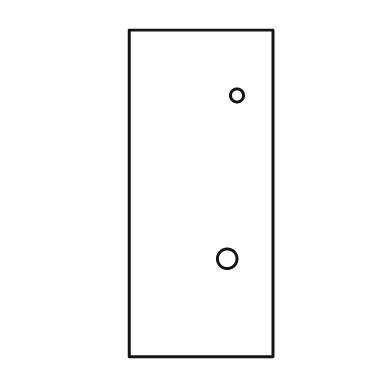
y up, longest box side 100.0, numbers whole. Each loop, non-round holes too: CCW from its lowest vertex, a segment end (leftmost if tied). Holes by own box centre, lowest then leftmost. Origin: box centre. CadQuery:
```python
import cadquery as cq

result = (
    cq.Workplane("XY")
    .moveTo(-22.0, -50.0)
    .lineTo(22.0, -50.0)
    .lineTo(22.0, 50.0)
    .lineTo(-22.0, 50.0)
    .close()
    .moveTo(8.0, -20.0)
    .circle(3.0)
    .moveTo(11.0, 30.0)
    .circle(2.0)
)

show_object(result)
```